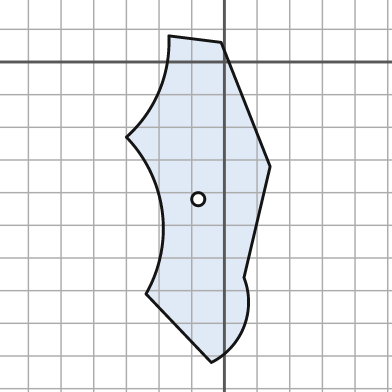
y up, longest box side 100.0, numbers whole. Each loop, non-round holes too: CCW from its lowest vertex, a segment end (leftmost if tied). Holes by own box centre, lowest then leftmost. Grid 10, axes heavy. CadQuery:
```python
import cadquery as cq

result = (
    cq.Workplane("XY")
    .moveTo(-4.0, -92.0)
    .threePointArc((6.0, -81.0), (6.0, -66.0))
    .lineTo(14.0, -32.0)
    .lineTo(-1.0, 6.0)
    .lineTo(-17.0, 8.0)
    .threePointArc((-20.0, -9.0), (-30.0, -23.0))
    .threePointArc((-19.0, -46.0), (-24.0, -71.0))
    .close()
    .moveTo(-8.0, -42.0)
    .circle(2.0)
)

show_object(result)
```